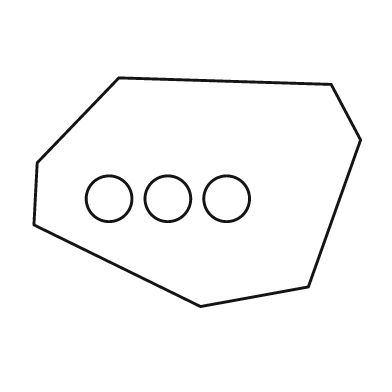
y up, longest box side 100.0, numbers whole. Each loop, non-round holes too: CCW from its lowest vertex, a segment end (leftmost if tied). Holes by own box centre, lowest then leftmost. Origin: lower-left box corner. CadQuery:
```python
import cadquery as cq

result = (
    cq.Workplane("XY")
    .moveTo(51.0, 0.0)
    .lineTo(84.0, 6.0)
    .lineTo(100.0, 51.0)
    .lineTo(91.0, 68.0)
    .lineTo(26.0, 70.0)
    .lineTo(1.0, 44.0)
    .lineTo(0.0, 25.0)
    .close()
    .moveTo(23.0, 33.0)
    .circle(7.0)
    .moveTo(41.0, 33.0)
    .circle(7.0)
    .moveTo(59.0, 33.0)
    .circle(7.0)
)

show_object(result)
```